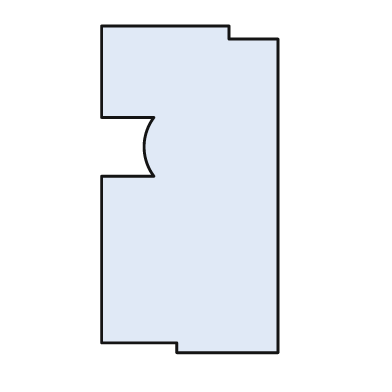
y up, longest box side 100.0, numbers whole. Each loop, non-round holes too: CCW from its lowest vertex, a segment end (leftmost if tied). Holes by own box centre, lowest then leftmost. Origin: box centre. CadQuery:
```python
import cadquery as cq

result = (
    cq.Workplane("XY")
    .moveTo(-4.0, -50.0)
    .lineTo(27.0, -50.0)
    .lineTo(27.0, 46.0)
    .lineTo(12.0, 46.0)
    .lineTo(12.0, 50.0)
    .lineTo(-27.0, 50.0)
    .lineTo(-27.0, 22.0)
    .lineTo(-11.0, 22.0)
    .threePointArc((-14.0, 13.0), (-11.0, 4.0))
    .lineTo(-27.0, 4.0)
    .lineTo(-27.0, -47.0)
    .lineTo(-4.0, -47.0)
    .close()
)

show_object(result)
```